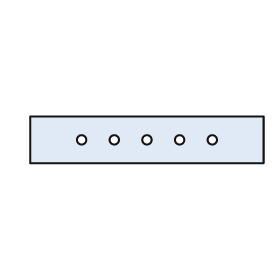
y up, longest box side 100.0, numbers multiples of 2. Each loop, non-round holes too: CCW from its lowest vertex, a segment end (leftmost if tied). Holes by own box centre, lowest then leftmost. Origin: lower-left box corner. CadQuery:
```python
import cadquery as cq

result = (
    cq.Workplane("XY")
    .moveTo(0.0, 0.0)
    .lineTo(100.0, 0.0)
    .lineTo(100.0, 20.0)
    .lineTo(0.0, 20.0)
    .close()
    .moveTo(22.0, 10.0)
    .circle(2.0)
    .moveTo(36.0, 10.0)
    .circle(2.0)
    .moveTo(50.0, 10.0)
    .circle(2.0)
    .moveTo(64.0, 10.0)
    .circle(2.0)
    .moveTo(78.0, 10.0)
    .circle(2.0)
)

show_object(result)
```